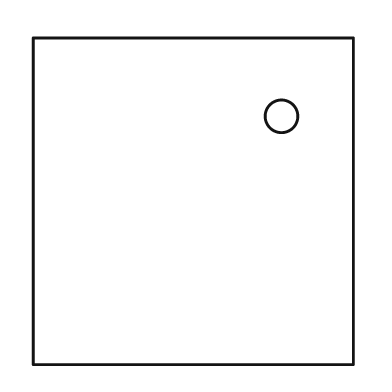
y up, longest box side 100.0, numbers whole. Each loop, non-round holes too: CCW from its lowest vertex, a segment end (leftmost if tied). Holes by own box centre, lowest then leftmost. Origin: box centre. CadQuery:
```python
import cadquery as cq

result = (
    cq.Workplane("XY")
    .moveTo(-49.0, -50.0)
    .lineTo(49.0, -50.0)
    .lineTo(49.0, 50.0)
    .lineTo(-49.0, 50.0)
    .close()
    .moveTo(27.0, 26.0)
    .circle(5.0)
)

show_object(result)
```